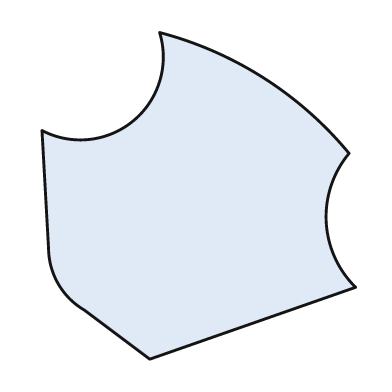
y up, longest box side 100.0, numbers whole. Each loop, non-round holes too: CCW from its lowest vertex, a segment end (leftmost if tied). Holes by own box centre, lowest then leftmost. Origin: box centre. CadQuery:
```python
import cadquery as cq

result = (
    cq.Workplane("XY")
    .moveTo(-15.0, -50.0)
    .lineTo(48.0, -28.0)
    .threePointArc((39.0, -8.0), (46.0, 13.0))
    .threePointArc((20.0, 36.0), (-12.0, 50.0))
    .threePointArc((-20.0, 23.0), (-48.0, 20.0))
    .lineTo(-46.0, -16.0)
    .threePointArc((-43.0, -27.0), (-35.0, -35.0))
    .close()
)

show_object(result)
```